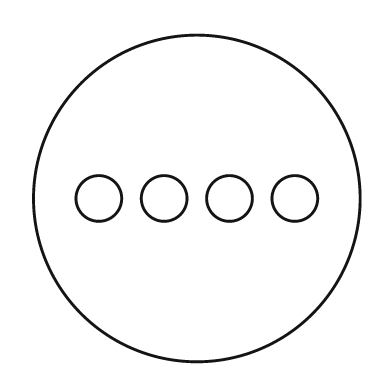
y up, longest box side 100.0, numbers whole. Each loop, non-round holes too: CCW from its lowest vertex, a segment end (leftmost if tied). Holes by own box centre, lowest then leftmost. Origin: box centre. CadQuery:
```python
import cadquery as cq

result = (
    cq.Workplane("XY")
    .moveTo(0.0, 0.0)
    .circle(50.0)
    .moveTo(-30.0, 0.0)
    .circle(7.0)
    .moveTo(-10.0, 0.0)
    .circle(7.0)
    .moveTo(10.0, 0.0)
    .circle(7.0)
    .moveTo(30.0, 0.0)
    .circle(7.0)
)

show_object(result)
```